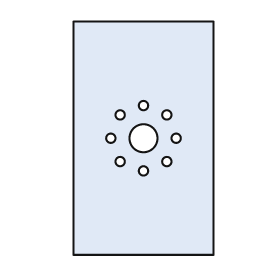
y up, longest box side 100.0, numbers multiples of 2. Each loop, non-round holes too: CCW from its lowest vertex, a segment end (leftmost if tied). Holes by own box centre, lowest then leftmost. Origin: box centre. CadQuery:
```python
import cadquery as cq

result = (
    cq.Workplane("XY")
    .moveTo(-30.0, -50.0)
    .lineTo(30.0, -50.0)
    .lineTo(30.0, 50.0)
    .lineTo(-30.0, 50.0)
    .close()
    .moveTo(0.0, -14.0)
    .circle(2.0)
    .moveTo(-10.0, -10.0)
    .circle(2.0)
    .moveTo(10.0, -10.0)
    .circle(2.0)
    .moveTo(-14.0, 0.0)
    .circle(2.0)
    .moveTo(0.0, 0.0)
    .circle(6.0)
    .moveTo(14.0, 0.0)
    .circle(2.0)
    .moveTo(-10.0, 10.0)
    .circle(2.0)
    .moveTo(10.0, 10.0)
    .circle(2.0)
    .moveTo(0.0, 14.0)
    .circle(2.0)
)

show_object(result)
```